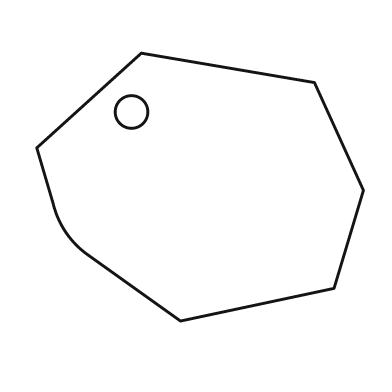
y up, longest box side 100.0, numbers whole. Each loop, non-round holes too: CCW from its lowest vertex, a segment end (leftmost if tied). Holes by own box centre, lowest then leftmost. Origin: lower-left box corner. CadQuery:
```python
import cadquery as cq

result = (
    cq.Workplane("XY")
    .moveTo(44.0, 0.0)
    .lineTo(91.0, 10.0)
    .lineTo(100.0, 40.0)
    .lineTo(85.0, 73.0)
    .lineTo(32.0, 82.0)
    .lineTo(0.0, 53.0)
    .lineTo(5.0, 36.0)
    .threePointArc((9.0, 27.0), (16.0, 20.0))
    .close()
    .moveTo(29.0, 64.0)
    .circle(5.0)
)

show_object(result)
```